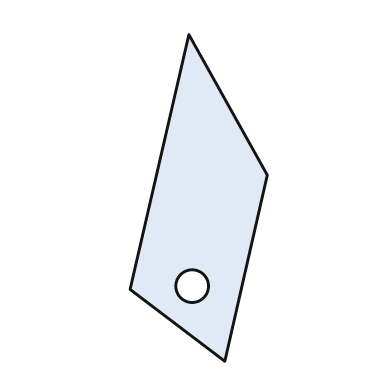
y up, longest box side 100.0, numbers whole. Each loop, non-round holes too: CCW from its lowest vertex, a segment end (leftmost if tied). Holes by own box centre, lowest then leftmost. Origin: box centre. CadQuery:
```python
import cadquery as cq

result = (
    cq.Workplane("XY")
    .moveTo(8.0, -50.0)
    .lineTo(21.0, 7.0)
    .lineTo(-3.0, 50.0)
    .lineTo(-21.0, -28.0)
    .close()
    .moveTo(-2.0, -27.0)
    .circle(5.0)
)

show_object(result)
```